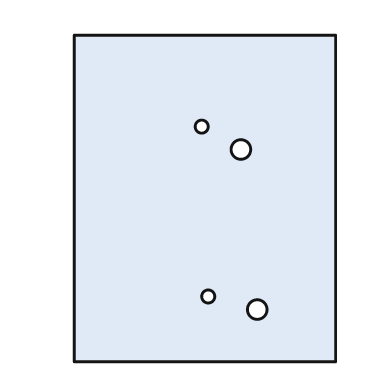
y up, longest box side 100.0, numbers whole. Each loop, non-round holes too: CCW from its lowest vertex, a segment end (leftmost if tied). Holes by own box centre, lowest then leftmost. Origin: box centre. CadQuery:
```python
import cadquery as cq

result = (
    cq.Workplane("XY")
    .moveTo(-40.0, -50.0)
    .lineTo(40.0, -50.0)
    .lineTo(40.0, 50.0)
    .lineTo(-40.0, 50.0)
    .close()
    .moveTo(16.0, -34.0)
    .circle(3.0)
    .moveTo(1.0, -30.0)
    .circle(2.0)
    .moveTo(11.0, 15.0)
    .circle(3.0)
    .moveTo(-1.0, 22.0)
    .circle(2.0)
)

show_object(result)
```